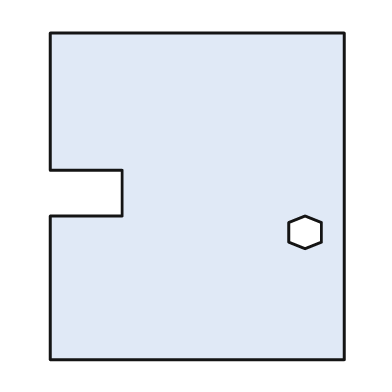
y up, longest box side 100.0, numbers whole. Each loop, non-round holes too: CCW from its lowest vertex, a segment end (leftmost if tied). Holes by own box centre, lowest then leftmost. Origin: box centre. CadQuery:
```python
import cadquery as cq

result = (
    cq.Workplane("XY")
    .moveTo(-45.0, -50.0)
    .lineTo(45.0, -50.0)
    .lineTo(45.0, 50.0)
    .lineTo(-45.0, 50.0)
    .lineTo(-45.0, 8.0)
    .lineTo(-23.0, 8.0)
    .lineTo(-23.0, -6.0)
    .lineTo(-45.0, -6.0)
    .close()
    .moveTo(33.0, -16.0)
    .lineTo(38.0, -14.0)
    .lineTo(38.0, -8.0)
    .lineTo(33.0, -6.0)
    .lineTo(28.0, -8.0)
    .lineTo(28.0, -14.0)
    .close()
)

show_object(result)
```